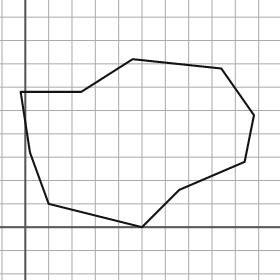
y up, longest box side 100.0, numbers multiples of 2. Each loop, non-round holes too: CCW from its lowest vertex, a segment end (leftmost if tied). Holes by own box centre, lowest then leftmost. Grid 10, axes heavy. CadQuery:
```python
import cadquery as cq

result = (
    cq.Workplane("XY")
    .moveTo(50.0, 0.0)
    .lineTo(66.0, 16.0)
    .lineTo(94.0, 28.0)
    .lineTo(98.0, 48.0)
    .lineTo(84.0, 68.0)
    .lineTo(46.0, 72.0)
    .lineTo(24.0, 58.0)
    .lineTo(-2.0, 58.0)
    .lineTo(2.0, 32.0)
    .lineTo(10.0, 10.0)
    .close()
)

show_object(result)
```